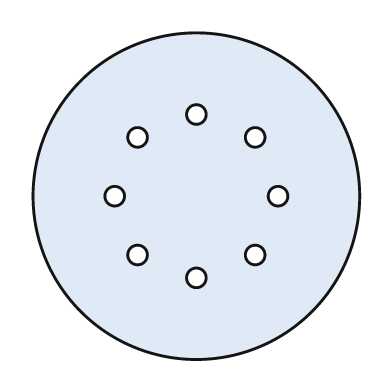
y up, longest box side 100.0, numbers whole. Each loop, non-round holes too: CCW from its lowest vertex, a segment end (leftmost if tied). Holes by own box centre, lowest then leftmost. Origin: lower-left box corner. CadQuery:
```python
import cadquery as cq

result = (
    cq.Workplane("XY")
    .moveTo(50.0, 50.0)
    .circle(50.0)
    .moveTo(50.0, 25.0)
    .circle(3.0)
    .moveTo(32.0, 32.0)
    .circle(3.0)
    .moveTo(68.0, 32.0)
    .circle(3.0)
    .moveTo(25.0, 50.0)
    .circle(3.0)
    .moveTo(75.0, 50.0)
    .circle(3.0)
    .moveTo(32.0, 68.0)
    .circle(3.0)
    .moveTo(68.0, 68.0)
    .circle(3.0)
    .moveTo(50.0, 75.0)
    .circle(3.0)
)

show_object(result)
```